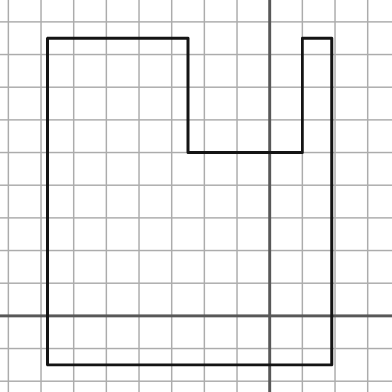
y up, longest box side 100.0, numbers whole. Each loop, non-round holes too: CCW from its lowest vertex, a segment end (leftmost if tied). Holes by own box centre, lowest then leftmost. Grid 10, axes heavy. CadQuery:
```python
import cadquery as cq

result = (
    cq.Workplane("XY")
    .moveTo(-68.0, -15.0)
    .lineTo(19.0, -15.0)
    .lineTo(19.0, 85.0)
    .lineTo(10.0, 85.0)
    .lineTo(10.0, 50.0)
    .lineTo(-25.0, 50.0)
    .lineTo(-25.0, 85.0)
    .lineTo(-68.0, 85.0)
    .close()
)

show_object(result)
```